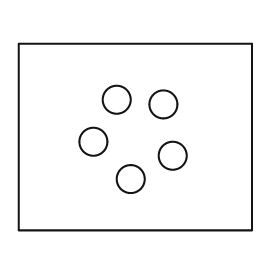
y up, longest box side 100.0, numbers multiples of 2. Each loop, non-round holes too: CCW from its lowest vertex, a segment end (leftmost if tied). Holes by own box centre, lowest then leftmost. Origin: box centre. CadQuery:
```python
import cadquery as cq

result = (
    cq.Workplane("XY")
    .moveTo(-50.0, -40.0)
    .lineTo(50.0, -40.0)
    .lineTo(50.0, 40.0)
    .lineTo(-50.0, 40.0)
    .close()
    .moveTo(-2.0, -18.0)
    .circle(6.0)
    .moveTo(16.0, -8.0)
    .circle(6.0)
    .moveTo(-18.0, -2.0)
    .circle(6.0)
    .moveTo(12.0, 14.0)
    .circle(6.0)
    .moveTo(-8.0, 16.0)
    .circle(6.0)
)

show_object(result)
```